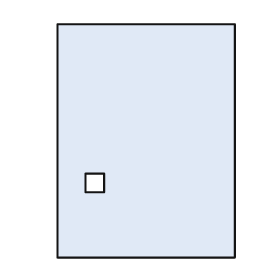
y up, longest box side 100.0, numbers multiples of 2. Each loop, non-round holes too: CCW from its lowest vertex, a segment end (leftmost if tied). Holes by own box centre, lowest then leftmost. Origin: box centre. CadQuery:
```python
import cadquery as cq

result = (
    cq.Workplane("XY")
    .moveTo(-38.0, -50.0)
    .lineTo(38.0, -50.0)
    .lineTo(38.0, 50.0)
    .lineTo(-38.0, 50.0)
    .close()
    .moveTo(-26.0, -22.0)
    .lineTo(-18.0, -22.0)
    .lineTo(-18.0, -14.0)
    .lineTo(-26.0, -14.0)
    .close()
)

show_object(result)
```